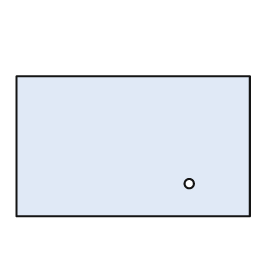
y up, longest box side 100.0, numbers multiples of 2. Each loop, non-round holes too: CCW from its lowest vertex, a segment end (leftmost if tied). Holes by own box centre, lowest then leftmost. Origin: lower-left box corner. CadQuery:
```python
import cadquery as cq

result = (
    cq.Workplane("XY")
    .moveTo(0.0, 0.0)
    .lineTo(100.0, 0.0)
    .lineTo(100.0, 60.0)
    .lineTo(0.0, 60.0)
    .close()
    .moveTo(74.0, 14.0)
    .circle(2.0)
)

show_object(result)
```